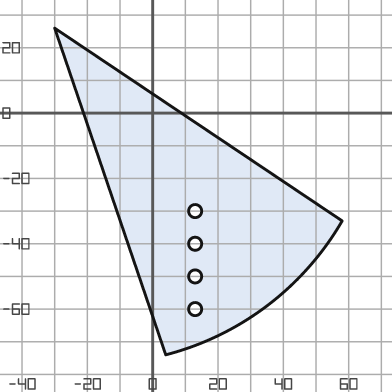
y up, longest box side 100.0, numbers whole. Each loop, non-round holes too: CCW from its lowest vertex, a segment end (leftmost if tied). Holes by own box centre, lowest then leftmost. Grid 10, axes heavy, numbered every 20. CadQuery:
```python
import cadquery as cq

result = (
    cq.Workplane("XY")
    .moveTo(4.0, -74.0)
    .threePointArc((35.0, -59.0), (58.0, -33.0))
    .lineTo(-30.0, 26.0)
    .close()
    .moveTo(13.0, -60.0)
    .circle(2.0)
    .moveTo(13.0, -50.0)
    .circle(2.0)
    .moveTo(13.0, -40.0)
    .circle(2.0)
    .moveTo(13.0, -30.0)
    .circle(2.0)
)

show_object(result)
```